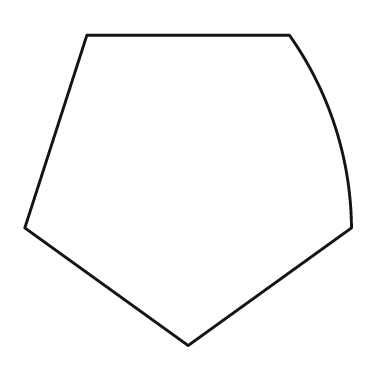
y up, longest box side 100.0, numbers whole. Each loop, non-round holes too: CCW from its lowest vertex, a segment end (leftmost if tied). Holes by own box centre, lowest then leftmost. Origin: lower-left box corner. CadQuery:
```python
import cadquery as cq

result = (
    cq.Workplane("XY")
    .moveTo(50.0, 0.0)
    .lineTo(100.0, 36.0)
    .threePointArc((95.0, 67.0), (81.0, 95.0))
    .lineTo(19.0, 95.0)
    .lineTo(0.0, 36.0)
    .close()
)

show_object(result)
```